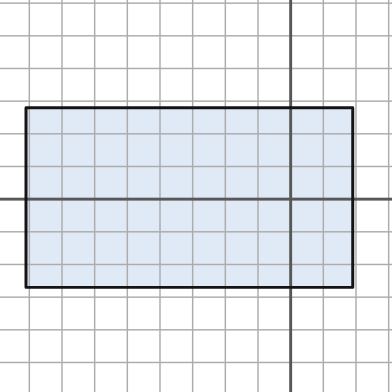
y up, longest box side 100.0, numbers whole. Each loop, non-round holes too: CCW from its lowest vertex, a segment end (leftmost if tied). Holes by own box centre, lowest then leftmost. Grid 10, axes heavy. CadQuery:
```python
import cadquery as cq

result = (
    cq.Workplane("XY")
    .moveTo(-81.0, -27.0)
    .lineTo(19.0, -27.0)
    .lineTo(19.0, 28.0)
    .lineTo(-81.0, 28.0)
    .close()
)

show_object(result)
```